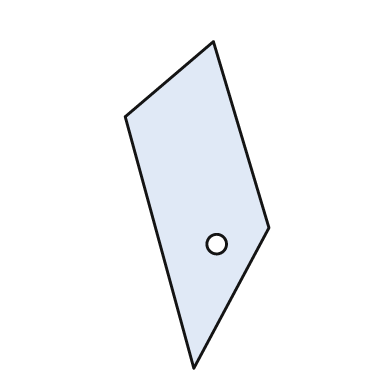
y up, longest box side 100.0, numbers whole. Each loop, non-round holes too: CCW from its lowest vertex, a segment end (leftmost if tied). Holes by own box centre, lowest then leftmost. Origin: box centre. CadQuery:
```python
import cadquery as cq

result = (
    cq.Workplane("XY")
    .moveTo(-1.0, -50.0)
    .lineTo(22.0, -7.0)
    .lineTo(5.0, 50.0)
    .lineTo(-22.0, 27.0)
    .close()
    .moveTo(6.0, -12.0)
    .circle(3.0)
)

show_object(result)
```